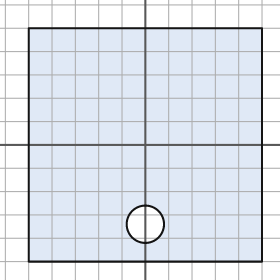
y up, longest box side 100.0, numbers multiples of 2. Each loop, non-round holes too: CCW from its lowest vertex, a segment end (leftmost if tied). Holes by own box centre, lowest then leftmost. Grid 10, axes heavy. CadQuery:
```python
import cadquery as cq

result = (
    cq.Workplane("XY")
    .moveTo(-50.0, -50.0)
    .lineTo(50.0, -50.0)
    .lineTo(50.0, 50.0)
    .lineTo(-50.0, 50.0)
    .close()
    .moveTo(0.0, -34.0)
    .circle(8.0)
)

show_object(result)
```